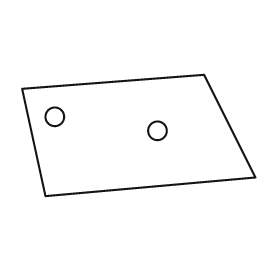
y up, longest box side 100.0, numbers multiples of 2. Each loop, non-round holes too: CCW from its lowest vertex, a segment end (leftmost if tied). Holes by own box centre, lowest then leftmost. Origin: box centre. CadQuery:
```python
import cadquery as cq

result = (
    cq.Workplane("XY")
    .moveTo(-40.0, -26.0)
    .lineTo(50.0, -18.0)
    .lineTo(28.0, 26.0)
    .lineTo(-50.0, 20.0)
    .close()
    .moveTo(8.0, 2.0)
    .circle(4.0)
    .moveTo(-36.0, 8.0)
    .circle(4.0)
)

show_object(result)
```